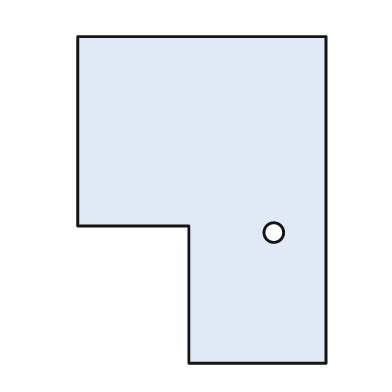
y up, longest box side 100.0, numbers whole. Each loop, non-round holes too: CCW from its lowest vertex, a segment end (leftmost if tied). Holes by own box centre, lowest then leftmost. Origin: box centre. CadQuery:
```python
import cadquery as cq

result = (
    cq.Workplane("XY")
    .moveTo(-4.0, -50.0)
    .lineTo(38.0, -50.0)
    .lineTo(38.0, 50.0)
    .lineTo(-38.0, 50.0)
    .lineTo(-38.0, -8.0)
    .lineTo(-4.0, -8.0)
    .close()
    .moveTo(22.0, -10.0)
    .circle(3.0)
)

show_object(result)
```